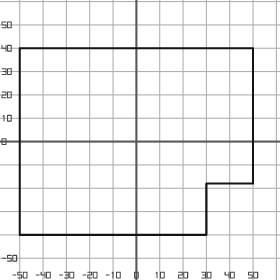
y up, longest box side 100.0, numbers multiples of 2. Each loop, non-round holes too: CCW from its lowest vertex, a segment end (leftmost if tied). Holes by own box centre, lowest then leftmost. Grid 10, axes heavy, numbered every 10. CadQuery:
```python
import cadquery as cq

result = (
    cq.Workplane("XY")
    .moveTo(-50.0, -40.0)
    .lineTo(30.0, -40.0)
    .lineTo(30.0, -18.0)
    .lineTo(50.0, -18.0)
    .lineTo(50.0, 40.0)
    .lineTo(-50.0, 40.0)
    .close()
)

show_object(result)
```